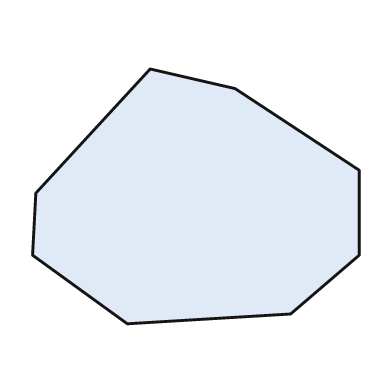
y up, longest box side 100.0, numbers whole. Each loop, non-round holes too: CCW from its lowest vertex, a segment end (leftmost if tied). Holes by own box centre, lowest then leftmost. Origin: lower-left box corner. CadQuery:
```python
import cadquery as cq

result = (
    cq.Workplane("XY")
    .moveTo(29.0, 0.0)
    .lineTo(79.0, 3.0)
    .lineTo(100.0, 21.0)
    .lineTo(100.0, 47.0)
    .lineTo(62.0, 72.0)
    .lineTo(36.0, 78.0)
    .lineTo(1.0, 40.0)
    .lineTo(0.0, 21.0)
    .close()
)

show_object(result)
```